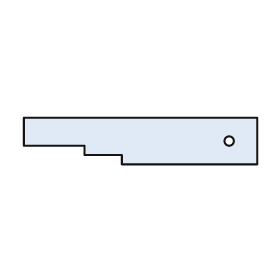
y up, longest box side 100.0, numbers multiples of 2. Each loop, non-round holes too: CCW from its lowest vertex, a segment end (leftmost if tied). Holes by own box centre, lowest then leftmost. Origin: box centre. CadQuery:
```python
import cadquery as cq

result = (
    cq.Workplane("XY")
    .moveTo(-8.0, -10.0)
    .lineTo(50.0, -10.0)
    .lineTo(50.0, 10.0)
    .lineTo(-50.0, 10.0)
    .lineTo(-50.0, -2.0)
    .lineTo(-24.0, -2.0)
    .lineTo(-24.0, -6.0)
    .lineTo(-8.0, -6.0)
    .close()
    .moveTo(38.0, 0.0)
    .circle(2.0)
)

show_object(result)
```